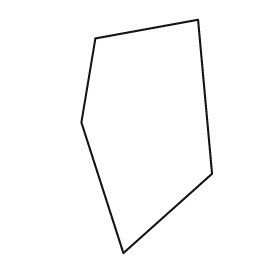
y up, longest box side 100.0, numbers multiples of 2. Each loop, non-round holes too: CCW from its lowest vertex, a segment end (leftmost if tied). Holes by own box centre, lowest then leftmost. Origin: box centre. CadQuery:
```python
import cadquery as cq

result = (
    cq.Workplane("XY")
    .moveTo(-10.0, -50.0)
    .lineTo(28.0, -16.0)
    .lineTo(22.0, 50.0)
    .lineTo(-22.0, 42.0)
    .lineTo(-28.0, 6.0)
    .close()
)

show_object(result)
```